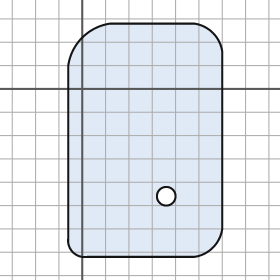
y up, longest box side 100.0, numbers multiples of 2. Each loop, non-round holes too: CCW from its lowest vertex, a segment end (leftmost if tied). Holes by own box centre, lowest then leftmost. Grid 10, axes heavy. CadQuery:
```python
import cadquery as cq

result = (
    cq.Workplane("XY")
    .moveTo(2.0, -72.0)
    .lineTo(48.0, -72.0)
    .threePointArc((56.0, -68.0), (60.0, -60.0))
    .lineTo(60.0, 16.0)
    .threePointArc((56.0, 24.0), (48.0, 28.0))
    .lineTo(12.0, 28.0)
    .threePointArc((0.0, 22.0), (-6.0, 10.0))
    .lineTo(-6.0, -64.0)
    .threePointArc((-4.0, -70.0), (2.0, -72.0))
    .close()
    .moveTo(36.0, -46.0)
    .circle(4.0)
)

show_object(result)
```